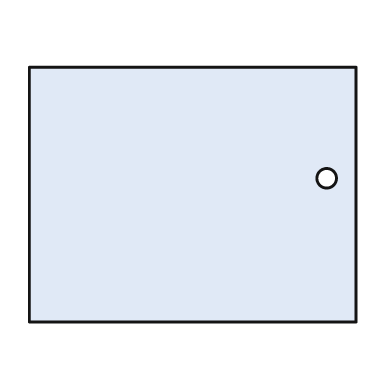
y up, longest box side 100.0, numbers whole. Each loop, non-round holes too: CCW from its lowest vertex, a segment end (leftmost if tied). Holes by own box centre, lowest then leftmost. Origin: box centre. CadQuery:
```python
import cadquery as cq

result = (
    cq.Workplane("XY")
    .moveTo(-50.0, -39.0)
    .lineTo(50.0, -39.0)
    .lineTo(50.0, 39.0)
    .lineTo(-50.0, 39.0)
    .close()
    .moveTo(41.0, 5.0)
    .circle(3.0)
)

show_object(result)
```